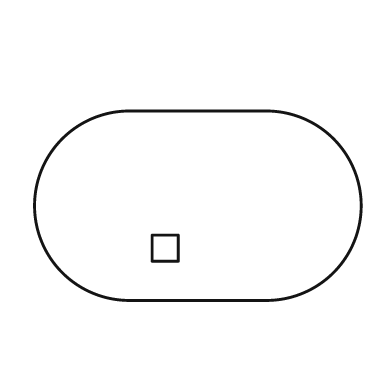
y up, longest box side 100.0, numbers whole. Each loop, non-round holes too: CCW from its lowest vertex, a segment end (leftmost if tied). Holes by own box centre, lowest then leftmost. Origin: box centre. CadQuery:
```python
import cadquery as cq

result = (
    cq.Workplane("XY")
    .moveTo(-21.0, -29.0)
    .lineTo(21.0, -29.0)
    .threePointArc((50.0, 0.0), (21.0, 29.0))
    .lineTo(-21.0, 29.0)
    .threePointArc((-50.0, 0.0), (-21.0, -29.0))
    .close()
    .moveTo(-14.0, -17.0)
    .lineTo(-6.0, -17.0)
    .lineTo(-6.0, -9.0)
    .lineTo(-14.0, -9.0)
    .close()
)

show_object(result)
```